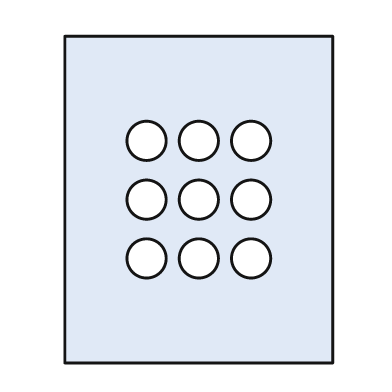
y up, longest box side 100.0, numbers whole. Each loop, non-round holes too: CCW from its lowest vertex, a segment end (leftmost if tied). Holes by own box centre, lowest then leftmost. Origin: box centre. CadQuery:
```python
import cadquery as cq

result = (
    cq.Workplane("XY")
    .moveTo(-41.0, -50.0)
    .lineTo(41.0, -50.0)
    .lineTo(41.0, 50.0)
    .lineTo(-41.0, 50.0)
    .close()
    .moveTo(-16.0, -18.0)
    .circle(6.0)
    .moveTo(0.0, -18.0)
    .circle(6.0)
    .moveTo(16.0, -18.0)
    .circle(6.0)
    .moveTo(-16.0, 0.0)
    .circle(6.0)
    .moveTo(0.0, 0.0)
    .circle(6.0)
    .moveTo(16.0, 0.0)
    .circle(6.0)
    .moveTo(-16.0, 18.0)
    .circle(6.0)
    .moveTo(0.0, 18.0)
    .circle(6.0)
    .moveTo(16.0, 18.0)
    .circle(6.0)
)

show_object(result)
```